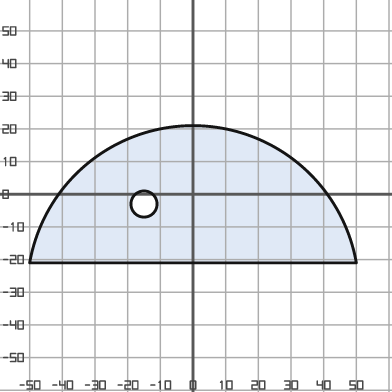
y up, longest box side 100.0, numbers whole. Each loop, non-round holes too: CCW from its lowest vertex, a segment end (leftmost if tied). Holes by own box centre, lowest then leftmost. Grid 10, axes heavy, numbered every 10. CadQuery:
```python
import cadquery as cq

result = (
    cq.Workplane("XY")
    .moveTo(-50.0, -21.0)
    .lineTo(50.0, -21.0)
    .threePointArc((0.0, 21.0), (-50.0, -21.0))
    .close()
    .moveTo(-15.0, -3.0)
    .circle(4.0)
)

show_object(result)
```